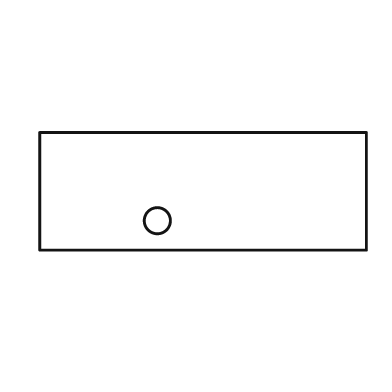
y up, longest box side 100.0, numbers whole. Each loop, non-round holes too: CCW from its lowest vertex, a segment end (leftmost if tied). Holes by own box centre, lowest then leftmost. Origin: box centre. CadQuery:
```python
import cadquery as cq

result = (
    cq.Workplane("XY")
    .moveTo(-50.0, -18.0)
    .lineTo(50.0, -18.0)
    .lineTo(50.0, 18.0)
    .lineTo(-50.0, 18.0)
    .close()
    .moveTo(-14.0, -9.0)
    .circle(4.0)
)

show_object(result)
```